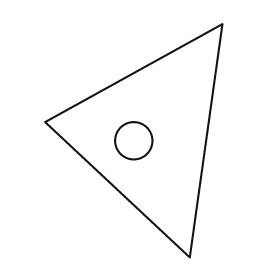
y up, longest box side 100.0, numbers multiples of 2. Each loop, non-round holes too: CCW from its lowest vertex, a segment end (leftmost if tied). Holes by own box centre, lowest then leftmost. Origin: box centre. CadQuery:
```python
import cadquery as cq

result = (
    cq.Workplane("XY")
    .moveTo(24.0, -50.0)
    .lineTo(38.0, 50.0)
    .lineTo(-38.0, 8.0)
    .close()
    .moveTo(0.0, 0.0)
    .circle(8.0)
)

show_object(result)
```